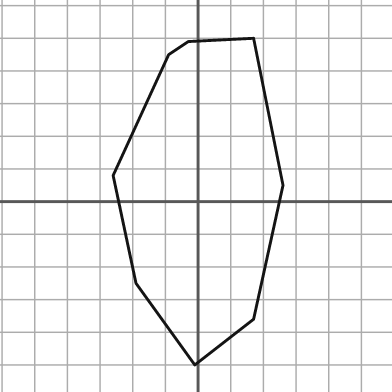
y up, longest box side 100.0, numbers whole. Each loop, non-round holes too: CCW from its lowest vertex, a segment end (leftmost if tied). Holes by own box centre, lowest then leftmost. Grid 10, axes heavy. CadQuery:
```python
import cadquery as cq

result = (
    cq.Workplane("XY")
    .moveTo(-1.0, -50.0)
    .lineTo(17.0, -36.0)
    .lineTo(26.0, 5.0)
    .lineTo(17.0, 50.0)
    .lineTo(-3.0, 49.0)
    .lineTo(-9.0, 45.0)
    .lineTo(-26.0, 8.0)
    .lineTo(-19.0, -25.0)
    .close()
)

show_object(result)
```